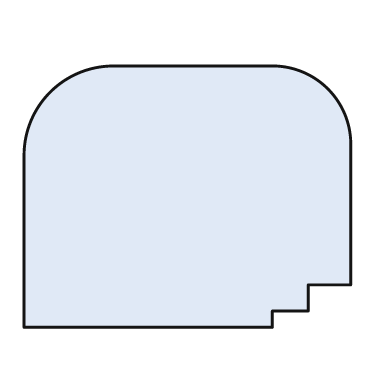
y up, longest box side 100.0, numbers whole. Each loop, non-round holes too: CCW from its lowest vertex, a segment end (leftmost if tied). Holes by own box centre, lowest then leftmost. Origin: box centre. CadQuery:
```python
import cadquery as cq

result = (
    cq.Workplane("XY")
    .moveTo(-50.0, -40.0)
    .lineTo(26.0, -40.0)
    .lineTo(26.0, -35.0)
    .lineTo(37.0, -35.0)
    .lineTo(37.0, -27.0)
    .lineTo(50.0, -27.0)
    .lineTo(50.0, 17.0)
    .threePointArc((43.0, 33.0), (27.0, 40.0))
    .lineTo(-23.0, 40.0)
    .threePointArc((-42.0, 32.0), (-50.0, 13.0))
    .close()
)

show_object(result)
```